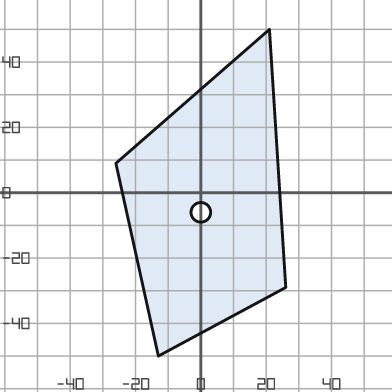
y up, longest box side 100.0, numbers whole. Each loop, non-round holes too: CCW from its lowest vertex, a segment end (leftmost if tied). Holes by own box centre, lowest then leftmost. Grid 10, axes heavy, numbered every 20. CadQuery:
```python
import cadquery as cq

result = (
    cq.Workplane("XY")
    .moveTo(-13.0, -50.0)
    .lineTo(26.0, -29.0)
    .lineTo(21.0, 50.0)
    .lineTo(-26.0, 9.0)
    .close()
    .moveTo(0.0, -6.0)
    .circle(3.0)
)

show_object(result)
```